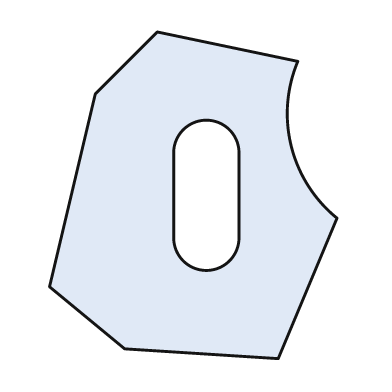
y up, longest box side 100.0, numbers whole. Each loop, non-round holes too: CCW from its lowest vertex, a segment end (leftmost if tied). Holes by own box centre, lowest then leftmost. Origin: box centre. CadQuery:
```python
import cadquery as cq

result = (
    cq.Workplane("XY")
    .moveTo(26.0, -50.0)
    .lineTo(44.0, -7.0)
    .threePointArc((30.0, 15.0), (32.0, 41.0))
    .lineTo(-11.0, 50.0)
    .lineTo(-30.0, 31.0)
    .lineTo(-44.0, -28.0)
    .lineTo(-21.0, -47.0)
    .close()
    .moveTo(-6.0, -13.0)
    .threePointArc((4.0, -23.0), (14.0, -13.0))
    .lineTo(14.0, 13.0)
    .threePointArc((4.0, 23.0), (-6.0, 13.0))
    .close()
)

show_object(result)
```